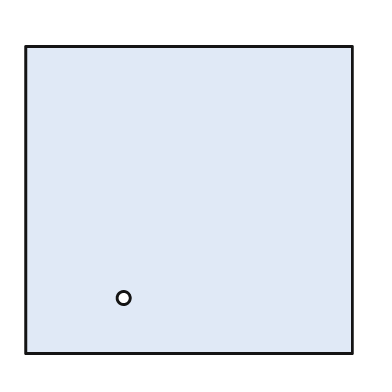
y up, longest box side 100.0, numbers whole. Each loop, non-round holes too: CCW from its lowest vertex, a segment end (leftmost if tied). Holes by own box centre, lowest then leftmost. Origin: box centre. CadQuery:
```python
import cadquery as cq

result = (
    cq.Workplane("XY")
    .moveTo(-50.0, -47.0)
    .lineTo(50.0, -47.0)
    .lineTo(50.0, 47.0)
    .lineTo(-50.0, 47.0)
    .close()
    .moveTo(-20.0, -30.0)
    .circle(2.0)
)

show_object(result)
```